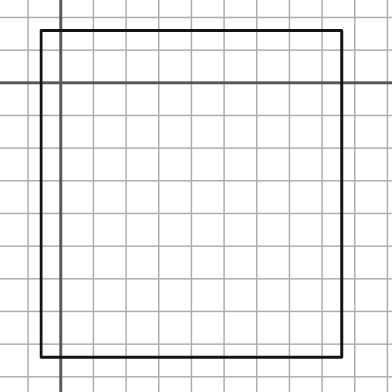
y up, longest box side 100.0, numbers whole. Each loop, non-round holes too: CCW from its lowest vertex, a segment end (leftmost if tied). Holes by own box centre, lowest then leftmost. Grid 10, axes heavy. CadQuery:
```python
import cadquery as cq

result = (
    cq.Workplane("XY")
    .moveTo(-6.0, -84.0)
    .lineTo(86.0, -84.0)
    .lineTo(86.0, 16.0)
    .lineTo(-6.0, 16.0)
    .close()
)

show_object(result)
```